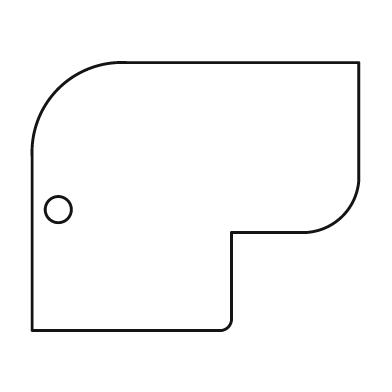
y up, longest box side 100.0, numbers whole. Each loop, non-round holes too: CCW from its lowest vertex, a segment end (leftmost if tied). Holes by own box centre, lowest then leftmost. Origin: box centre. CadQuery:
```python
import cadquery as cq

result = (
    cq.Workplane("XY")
    .moveTo(-50.0, -41.0)
    .lineTo(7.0, -41.0)
    .threePointArc((10.0, -40.0), (11.0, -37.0))
    .lineTo(11.0, -11.0)
    .lineTo(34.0, -11.0)
    .threePointArc((45.0, -6.0), (50.0, 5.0))
    .lineTo(50.0, 41.0)
    .lineTo(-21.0, 41.0)
    .threePointArc((-42.0, 33.0), (-50.0, 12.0))
    .close()
    .moveTo(-42.0, -4.0)
    .circle(4.0)
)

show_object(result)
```